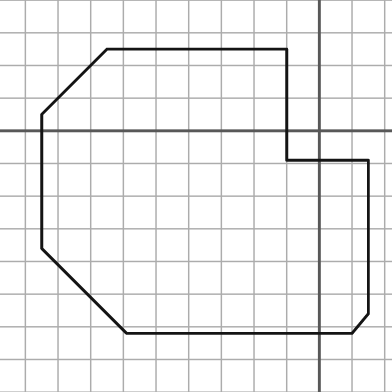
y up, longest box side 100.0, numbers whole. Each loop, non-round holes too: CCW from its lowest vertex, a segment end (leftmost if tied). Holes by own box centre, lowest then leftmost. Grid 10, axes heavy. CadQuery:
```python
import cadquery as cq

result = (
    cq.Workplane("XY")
    .moveTo(-59.0, -62.0)
    .lineTo(10.0, -62.0)
    .lineTo(15.0, -56.0)
    .lineTo(15.0, -9.0)
    .lineTo(-10.0, -9.0)
    .lineTo(-10.0, 25.0)
    .lineTo(-65.0, 25.0)
    .lineTo(-85.0, 5.0)
    .lineTo(-85.0, -36.0)
    .close()
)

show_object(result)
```